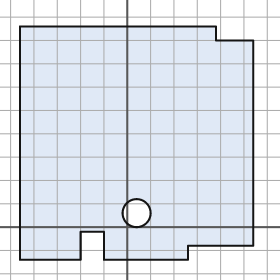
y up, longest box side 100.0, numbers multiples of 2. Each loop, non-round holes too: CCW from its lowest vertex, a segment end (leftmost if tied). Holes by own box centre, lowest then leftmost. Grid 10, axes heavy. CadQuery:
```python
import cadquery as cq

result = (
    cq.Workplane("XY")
    .moveTo(-46.0, -14.0)
    .lineTo(-20.0, -14.0)
    .lineTo(-20.0, -2.0)
    .lineTo(-10.0, -2.0)
    .lineTo(-10.0, -14.0)
    .lineTo(26.0, -14.0)
    .lineTo(26.0, -8.0)
    .lineTo(54.0, -8.0)
    .lineTo(54.0, 80.0)
    .lineTo(38.0, 80.0)
    .lineTo(38.0, 86.0)
    .lineTo(-46.0, 86.0)
    .close()
    .moveTo(4.0, 6.0)
    .circle(6.0)
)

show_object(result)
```